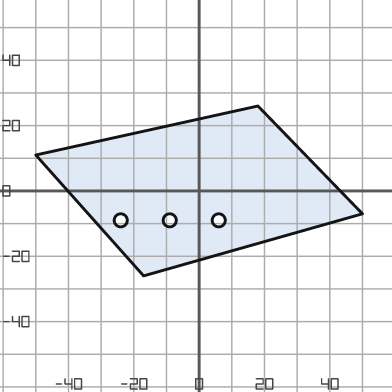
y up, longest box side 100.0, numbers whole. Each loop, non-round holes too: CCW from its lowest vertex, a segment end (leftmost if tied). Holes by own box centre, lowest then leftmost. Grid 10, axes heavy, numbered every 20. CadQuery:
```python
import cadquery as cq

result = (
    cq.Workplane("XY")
    .moveTo(-17.0, -26.0)
    .lineTo(50.0, -7.0)
    .lineTo(18.0, 26.0)
    .lineTo(-50.0, 11.0)
    .close()
    .moveTo(-24.0, -9.0)
    .circle(2.0)
    .moveTo(-9.0, -9.0)
    .circle(2.0)
    .moveTo(6.0, -9.0)
    .circle(2.0)
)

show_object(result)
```